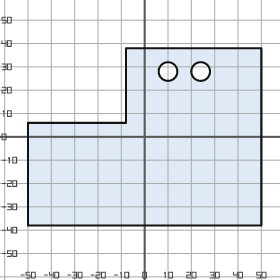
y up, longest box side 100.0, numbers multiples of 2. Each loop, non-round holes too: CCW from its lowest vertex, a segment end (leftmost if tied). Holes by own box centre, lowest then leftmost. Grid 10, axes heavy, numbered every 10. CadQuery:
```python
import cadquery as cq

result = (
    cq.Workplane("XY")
    .moveTo(-50.0, -38.0)
    .lineTo(50.0, -38.0)
    .lineTo(50.0, 38.0)
    .lineTo(-8.0, 38.0)
    .lineTo(-8.0, 6.0)
    .lineTo(-50.0, 6.0)
    .close()
    .moveTo(10.0, 28.0)
    .circle(4.0)
    .moveTo(24.0, 28.0)
    .circle(4.0)
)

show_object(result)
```